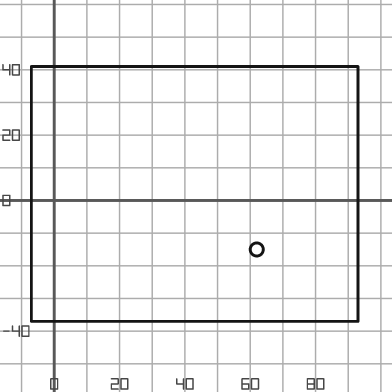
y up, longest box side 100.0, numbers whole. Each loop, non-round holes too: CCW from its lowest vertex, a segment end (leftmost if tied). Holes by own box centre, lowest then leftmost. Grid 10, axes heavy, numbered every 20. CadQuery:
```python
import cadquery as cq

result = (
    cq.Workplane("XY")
    .moveTo(-7.0, -37.0)
    .lineTo(93.0, -37.0)
    .lineTo(93.0, 41.0)
    .lineTo(-7.0, 41.0)
    .close()
    .moveTo(62.0, -15.0)
    .circle(2.0)
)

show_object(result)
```